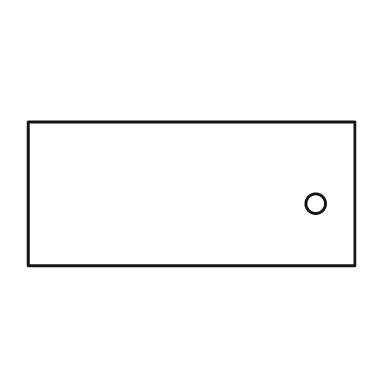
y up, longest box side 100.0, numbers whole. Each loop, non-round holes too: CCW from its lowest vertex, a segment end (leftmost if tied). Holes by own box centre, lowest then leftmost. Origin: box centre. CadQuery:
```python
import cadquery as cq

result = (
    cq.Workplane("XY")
    .moveTo(-50.0, -22.0)
    .lineTo(50.0, -22.0)
    .lineTo(50.0, 22.0)
    .lineTo(-50.0, 22.0)
    .close()
    .moveTo(38.0, -3.0)
    .circle(3.0)
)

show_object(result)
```